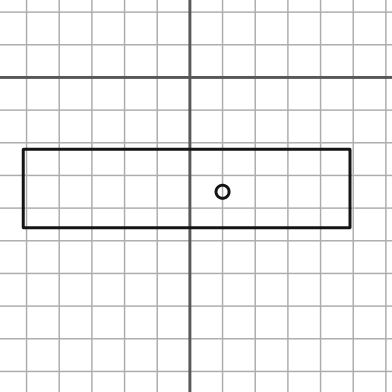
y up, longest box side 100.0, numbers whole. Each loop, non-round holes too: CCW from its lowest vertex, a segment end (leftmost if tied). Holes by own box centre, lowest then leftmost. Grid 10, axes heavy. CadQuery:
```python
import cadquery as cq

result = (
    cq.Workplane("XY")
    .moveTo(-51.0, -46.0)
    .lineTo(49.0, -46.0)
    .lineTo(49.0, -22.0)
    .lineTo(-51.0, -22.0)
    .close()
    .moveTo(10.0, -35.0)
    .circle(2.0)
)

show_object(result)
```